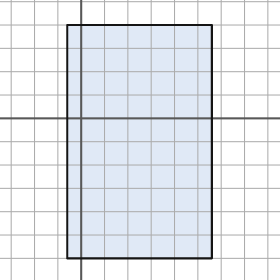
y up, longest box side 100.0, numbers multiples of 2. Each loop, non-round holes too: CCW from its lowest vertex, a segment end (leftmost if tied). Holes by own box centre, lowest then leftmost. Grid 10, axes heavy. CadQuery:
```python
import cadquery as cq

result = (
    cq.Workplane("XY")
    .moveTo(-6.0, -60.0)
    .lineTo(56.0, -60.0)
    .lineTo(56.0, 40.0)
    .lineTo(-6.0, 40.0)
    .close()
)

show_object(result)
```